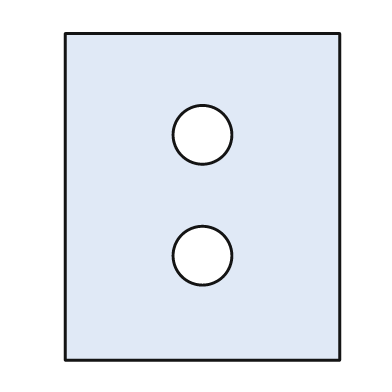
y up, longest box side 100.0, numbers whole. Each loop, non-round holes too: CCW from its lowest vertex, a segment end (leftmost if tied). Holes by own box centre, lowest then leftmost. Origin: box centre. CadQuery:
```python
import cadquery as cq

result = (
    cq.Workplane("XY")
    .moveTo(-42.0, -50.0)
    .lineTo(42.0, -50.0)
    .lineTo(42.0, 50.0)
    .lineTo(-42.0, 50.0)
    .close()
    .moveTo(0.0, -18.0)
    .circle(9.0)
    .moveTo(0.0, 19.0)
    .circle(9.0)
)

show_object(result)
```